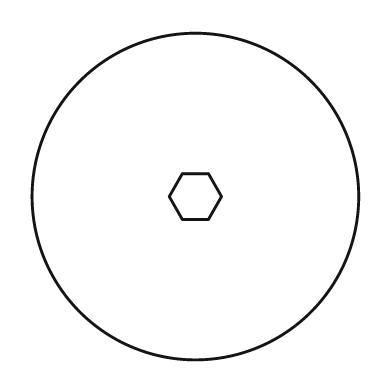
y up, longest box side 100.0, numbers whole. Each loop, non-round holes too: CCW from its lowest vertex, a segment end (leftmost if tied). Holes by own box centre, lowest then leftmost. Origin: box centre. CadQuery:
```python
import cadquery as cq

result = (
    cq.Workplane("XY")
    .moveTo(0.0, 0.0)
    .circle(50.0)
    .moveTo(-4.0, -7.0)
    .lineTo(4.0, -7.0)
    .lineTo(8.0, 0.0)
    .lineTo(4.0, 7.0)
    .lineTo(-4.0, 7.0)
    .lineTo(-8.0, 0.0)
    .close()
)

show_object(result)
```